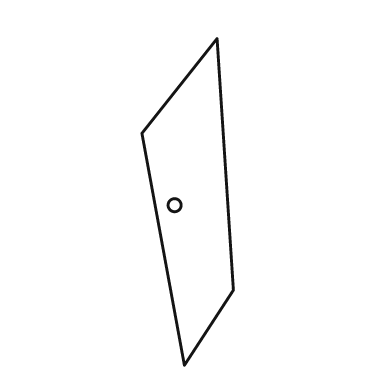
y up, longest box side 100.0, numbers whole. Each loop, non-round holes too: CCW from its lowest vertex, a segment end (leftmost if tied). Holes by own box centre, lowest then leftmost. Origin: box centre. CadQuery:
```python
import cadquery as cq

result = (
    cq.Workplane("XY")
    .moveTo(-1.0, -50.0)
    .lineTo(14.0, -27.0)
    .lineTo(9.0, 50.0)
    .lineTo(-14.0, 21.0)
    .close()
    .moveTo(-4.0, -1.0)
    .circle(2.0)
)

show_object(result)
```